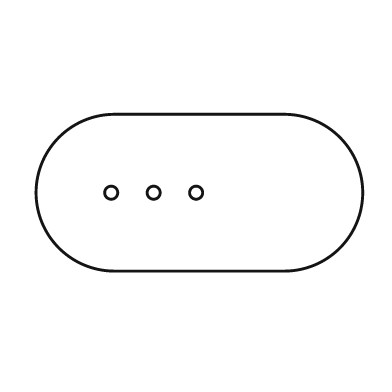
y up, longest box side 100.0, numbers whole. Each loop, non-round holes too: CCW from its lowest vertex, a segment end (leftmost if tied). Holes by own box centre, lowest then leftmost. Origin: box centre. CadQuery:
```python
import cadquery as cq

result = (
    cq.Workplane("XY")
    .moveTo(-26.0, -24.0)
    .lineTo(26.0, -24.0)
    .threePointArc((50.0, 0.0), (26.0, 24.0))
    .lineTo(-26.0, 24.0)
    .threePointArc((-50.0, 0.0), (-26.0, -24.0))
    .close()
    .moveTo(-27.0, 0.0)
    .circle(2.0)
    .moveTo(-14.0, 0.0)
    .circle(2.0)
    .moveTo(-1.0, 0.0)
    .circle(2.0)
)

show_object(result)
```